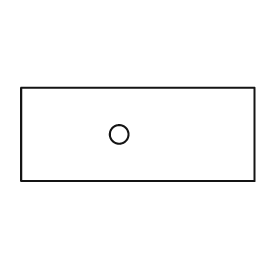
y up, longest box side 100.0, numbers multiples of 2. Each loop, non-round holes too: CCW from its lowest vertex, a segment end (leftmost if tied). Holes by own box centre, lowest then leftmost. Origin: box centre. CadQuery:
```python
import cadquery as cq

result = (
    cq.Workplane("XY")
    .moveTo(-50.0, -20.0)
    .lineTo(50.0, -20.0)
    .lineTo(50.0, 20.0)
    .lineTo(-50.0, 20.0)
    .close()
    .moveTo(-8.0, 0.0)
    .circle(4.0)
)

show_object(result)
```